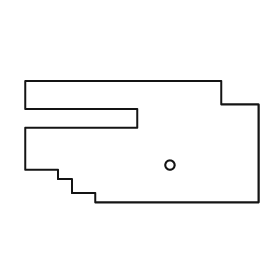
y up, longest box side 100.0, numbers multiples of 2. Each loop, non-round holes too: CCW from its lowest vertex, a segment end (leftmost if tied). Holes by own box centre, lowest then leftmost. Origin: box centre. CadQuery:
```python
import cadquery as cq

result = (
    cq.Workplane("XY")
    .moveTo(-20.0, -26.0)
    .lineTo(50.0, -26.0)
    .lineTo(50.0, 16.0)
    .lineTo(34.0, 16.0)
    .lineTo(34.0, 26.0)
    .lineTo(-50.0, 26.0)
    .lineTo(-50.0, 14.0)
    .lineTo(-2.0, 14.0)
    .lineTo(-2.0, 6.0)
    .lineTo(-50.0, 6.0)
    .lineTo(-50.0, -12.0)
    .lineTo(-36.0, -12.0)
    .lineTo(-36.0, -16.0)
    .lineTo(-30.0, -16.0)
    .lineTo(-30.0, -22.0)
    .lineTo(-20.0, -22.0)
    .close()
    .moveTo(12.0, -10.0)
    .circle(2.0)
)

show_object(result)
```